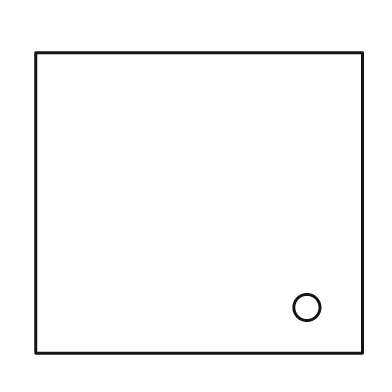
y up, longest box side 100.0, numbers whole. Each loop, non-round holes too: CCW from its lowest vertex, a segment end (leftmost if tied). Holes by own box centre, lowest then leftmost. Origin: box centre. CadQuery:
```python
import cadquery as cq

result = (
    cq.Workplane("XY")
    .moveTo(-50.0, -46.0)
    .lineTo(50.0, -46.0)
    .lineTo(50.0, 46.0)
    .lineTo(-50.0, 46.0)
    .close()
    .moveTo(33.0, -32.0)
    .circle(4.0)
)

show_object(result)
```